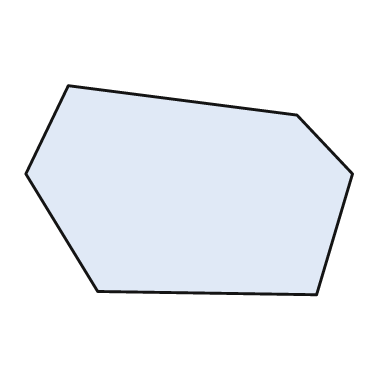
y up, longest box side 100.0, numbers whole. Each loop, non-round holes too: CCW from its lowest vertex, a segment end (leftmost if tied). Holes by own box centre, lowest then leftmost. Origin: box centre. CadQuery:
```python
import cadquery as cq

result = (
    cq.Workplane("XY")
    .moveTo(39.0, -32.0)
    .lineTo(50.0, 5.0)
    .lineTo(33.0, 23.0)
    .lineTo(-37.0, 32.0)
    .lineTo(-50.0, 5.0)
    .lineTo(-28.0, -31.0)
    .close()
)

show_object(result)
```